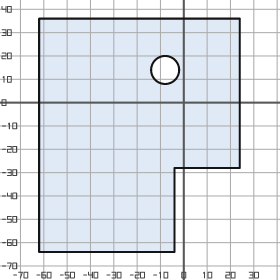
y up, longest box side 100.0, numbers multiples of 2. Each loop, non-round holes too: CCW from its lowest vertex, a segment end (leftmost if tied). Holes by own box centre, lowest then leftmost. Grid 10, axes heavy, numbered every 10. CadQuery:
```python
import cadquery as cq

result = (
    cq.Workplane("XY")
    .moveTo(-62.0, -64.0)
    .lineTo(-4.0, -64.0)
    .lineTo(-4.0, -28.0)
    .lineTo(24.0, -28.0)
    .lineTo(24.0, 36.0)
    .lineTo(-62.0, 36.0)
    .close()
    .moveTo(-8.0, 14.0)
    .circle(6.0)
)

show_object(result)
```